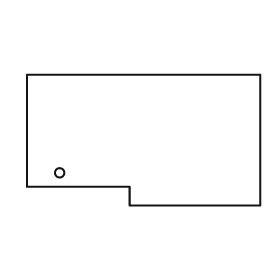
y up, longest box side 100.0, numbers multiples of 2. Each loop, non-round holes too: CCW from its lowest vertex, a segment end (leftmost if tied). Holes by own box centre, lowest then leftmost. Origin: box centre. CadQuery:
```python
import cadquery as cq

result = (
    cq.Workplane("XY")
    .moveTo(-6.0, -28.0)
    .lineTo(50.0, -28.0)
    .lineTo(50.0, 28.0)
    .lineTo(-50.0, 28.0)
    .lineTo(-50.0, -20.0)
    .lineTo(-6.0, -20.0)
    .close()
    .moveTo(-36.0, -14.0)
    .circle(2.0)
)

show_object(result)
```